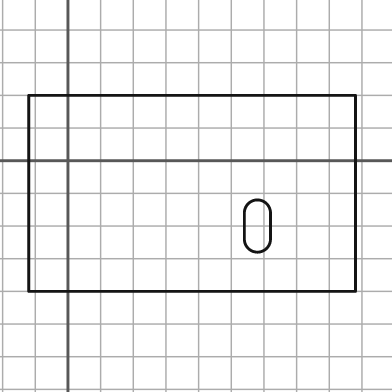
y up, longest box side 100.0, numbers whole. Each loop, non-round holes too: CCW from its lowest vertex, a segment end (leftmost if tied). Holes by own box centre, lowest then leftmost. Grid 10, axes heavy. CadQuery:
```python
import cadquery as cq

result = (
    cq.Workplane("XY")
    .moveTo(-12.0, -40.0)
    .lineTo(88.0, -40.0)
    .lineTo(88.0, 20.0)
    .lineTo(-12.0, 20.0)
    .close()
    .moveTo(54.0, -24.0)
    .threePointArc((58.0, -28.0), (62.0, -24.0))
    .lineTo(62.0, -16.0)
    .threePointArc((58.0, -12.0), (54.0, -16.0))
    .close()
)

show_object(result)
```